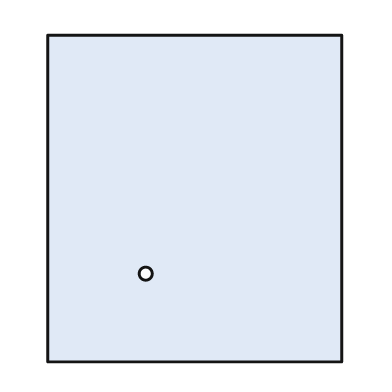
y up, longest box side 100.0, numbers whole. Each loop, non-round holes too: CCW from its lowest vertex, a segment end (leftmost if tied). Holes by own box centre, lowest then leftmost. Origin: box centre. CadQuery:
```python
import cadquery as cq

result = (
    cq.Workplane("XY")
    .moveTo(-45.0, -50.0)
    .lineTo(45.0, -50.0)
    .lineTo(45.0, 50.0)
    .lineTo(-45.0, 50.0)
    .close()
    .moveTo(-15.0, -23.0)
    .circle(2.0)
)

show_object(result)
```